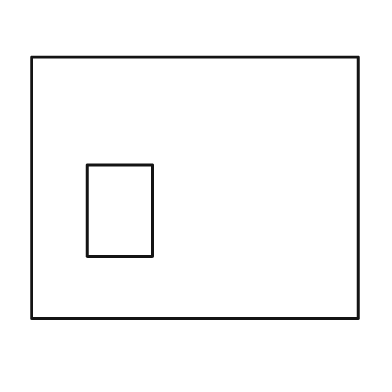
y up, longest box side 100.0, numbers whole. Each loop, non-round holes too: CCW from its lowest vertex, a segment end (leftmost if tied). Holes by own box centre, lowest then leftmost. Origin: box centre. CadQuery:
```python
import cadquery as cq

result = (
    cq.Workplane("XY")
    .moveTo(-50.0, -40.0)
    .lineTo(50.0, -40.0)
    .lineTo(50.0, 40.0)
    .lineTo(-50.0, 40.0)
    .close()
    .moveTo(-33.0, -21.0)
    .lineTo(-13.0, -21.0)
    .lineTo(-13.0, 7.0)
    .lineTo(-33.0, 7.0)
    .close()
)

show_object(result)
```